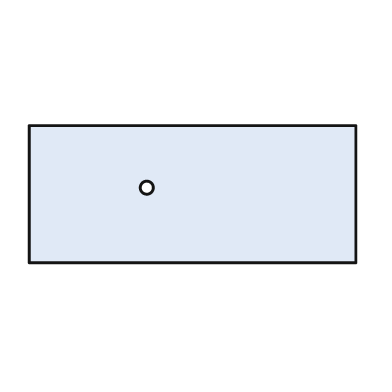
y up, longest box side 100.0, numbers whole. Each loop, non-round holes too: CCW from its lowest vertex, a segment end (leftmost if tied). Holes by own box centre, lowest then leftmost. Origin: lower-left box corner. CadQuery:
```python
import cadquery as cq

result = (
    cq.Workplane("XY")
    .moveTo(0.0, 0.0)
    .lineTo(100.0, 0.0)
    .lineTo(100.0, 42.0)
    .lineTo(0.0, 42.0)
    .close()
    .moveTo(36.0, 23.0)
    .circle(2.0)
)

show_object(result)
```